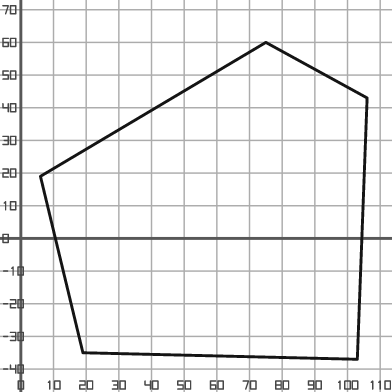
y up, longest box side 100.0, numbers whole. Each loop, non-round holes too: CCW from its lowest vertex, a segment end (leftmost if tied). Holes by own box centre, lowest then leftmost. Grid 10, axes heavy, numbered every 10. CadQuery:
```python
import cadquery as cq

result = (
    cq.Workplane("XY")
    .moveTo(103.0, -37.0)
    .lineTo(106.0, 43.0)
    .lineTo(75.0, 60.0)
    .lineTo(6.0, 19.0)
    .lineTo(19.0, -35.0)
    .close()
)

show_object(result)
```